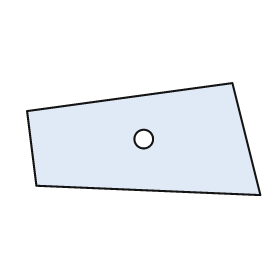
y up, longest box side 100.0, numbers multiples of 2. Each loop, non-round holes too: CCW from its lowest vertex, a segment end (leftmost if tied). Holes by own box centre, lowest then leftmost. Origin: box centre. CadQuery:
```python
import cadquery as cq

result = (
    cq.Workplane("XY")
    .moveTo(50.0, -24.0)
    .lineTo(38.0, 24.0)
    .lineTo(-50.0, 12.0)
    .lineTo(-46.0, -20.0)
    .close()
    .moveTo(0.0, 0.0)
    .circle(4.0)
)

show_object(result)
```